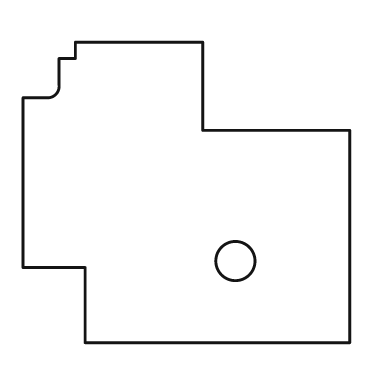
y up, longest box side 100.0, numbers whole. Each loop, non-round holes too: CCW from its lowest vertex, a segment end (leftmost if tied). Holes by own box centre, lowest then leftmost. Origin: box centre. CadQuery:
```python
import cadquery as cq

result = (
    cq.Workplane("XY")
    .moveTo(-31.0, -46.0)
    .lineTo(50.0, -46.0)
    .lineTo(50.0, 19.0)
    .lineTo(5.0, 19.0)
    .lineTo(5.0, 46.0)
    .lineTo(-34.0, 46.0)
    .lineTo(-34.0, 41.0)
    .lineTo(-39.0, 41.0)
    .lineTo(-39.0, 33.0)
    .threePointArc((-40.0, 30.0), (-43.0, 29.0))
    .lineTo(-50.0, 29.0)
    .lineTo(-50.0, -23.0)
    .lineTo(-31.0, -23.0)
    .close()
    .moveTo(15.0, -21.0)
    .circle(6.0)
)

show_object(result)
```